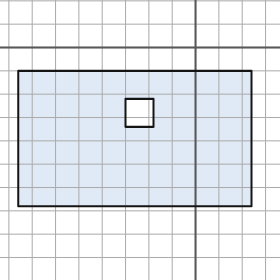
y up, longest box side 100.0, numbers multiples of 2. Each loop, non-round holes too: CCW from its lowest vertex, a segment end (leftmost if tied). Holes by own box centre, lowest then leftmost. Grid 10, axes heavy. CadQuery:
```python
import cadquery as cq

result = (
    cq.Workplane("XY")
    .moveTo(-76.0, -68.0)
    .lineTo(24.0, -68.0)
    .lineTo(24.0, -10.0)
    .lineTo(-76.0, -10.0)
    .close()
    .moveTo(-30.0, -34.0)
    .lineTo(-18.0, -34.0)
    .lineTo(-18.0, -22.0)
    .lineTo(-30.0, -22.0)
    .close()
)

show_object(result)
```